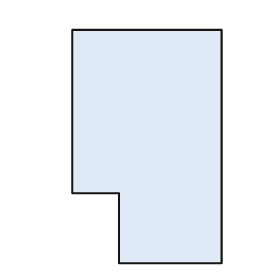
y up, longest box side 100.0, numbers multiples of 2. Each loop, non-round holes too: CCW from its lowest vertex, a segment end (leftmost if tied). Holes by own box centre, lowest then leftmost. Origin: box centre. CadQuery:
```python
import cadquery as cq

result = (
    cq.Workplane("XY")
    .moveTo(-12.0, -50.0)
    .lineTo(32.0, -50.0)
    .lineTo(32.0, 50.0)
    .lineTo(-32.0, 50.0)
    .lineTo(-32.0, -20.0)
    .lineTo(-12.0, -20.0)
    .close()
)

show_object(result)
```